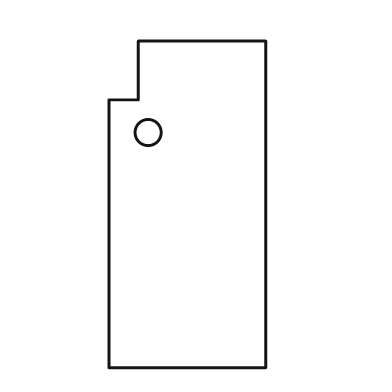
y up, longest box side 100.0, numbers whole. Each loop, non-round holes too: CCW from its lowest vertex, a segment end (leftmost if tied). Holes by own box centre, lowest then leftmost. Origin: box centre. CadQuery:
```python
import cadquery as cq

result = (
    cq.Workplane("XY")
    .moveTo(-24.0, -50.0)
    .lineTo(24.0, -50.0)
    .lineTo(24.0, 50.0)
    .lineTo(-15.0, 50.0)
    .lineTo(-15.0, 32.0)
    .lineTo(-24.0, 32.0)
    .close()
    .moveTo(-12.0, 22.0)
    .circle(4.0)
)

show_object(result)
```